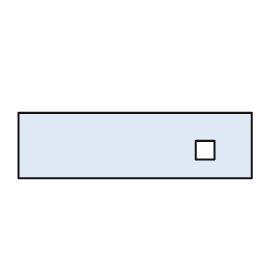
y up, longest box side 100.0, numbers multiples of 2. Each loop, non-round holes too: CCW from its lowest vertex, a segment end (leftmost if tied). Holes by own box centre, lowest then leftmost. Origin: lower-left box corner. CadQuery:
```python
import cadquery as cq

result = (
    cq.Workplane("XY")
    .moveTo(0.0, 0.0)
    .lineTo(100.0, 0.0)
    .lineTo(100.0, 28.0)
    .lineTo(0.0, 28.0)
    .close()
    .moveTo(76.0, 8.0)
    .lineTo(84.0, 8.0)
    .lineTo(84.0, 16.0)
    .lineTo(76.0, 16.0)
    .close()
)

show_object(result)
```